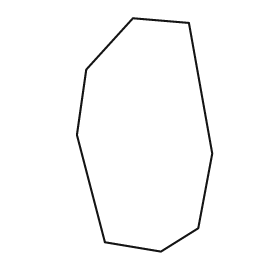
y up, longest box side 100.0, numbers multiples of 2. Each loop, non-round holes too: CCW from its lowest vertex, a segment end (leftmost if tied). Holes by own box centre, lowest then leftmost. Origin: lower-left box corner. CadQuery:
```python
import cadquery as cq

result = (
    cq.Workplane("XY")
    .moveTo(36.0, 0.0)
    .lineTo(52.0, 10.0)
    .lineTo(58.0, 42.0)
    .lineTo(48.0, 98.0)
    .lineTo(24.0, 100.0)
    .lineTo(4.0, 78.0)
    .lineTo(0.0, 50.0)
    .lineTo(12.0, 4.0)
    .close()
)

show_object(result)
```